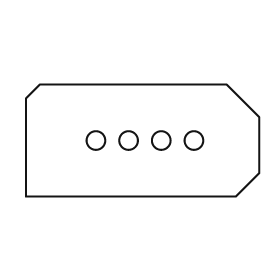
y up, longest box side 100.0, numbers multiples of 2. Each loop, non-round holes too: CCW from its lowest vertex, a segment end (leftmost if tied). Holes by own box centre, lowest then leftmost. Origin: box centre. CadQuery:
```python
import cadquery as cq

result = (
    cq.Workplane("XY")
    .moveTo(-50.0, -24.0)
    .lineTo(40.0, -24.0)
    .lineTo(50.0, -14.0)
    .lineTo(50.0, 10.0)
    .lineTo(36.0, 24.0)
    .lineTo(-44.0, 24.0)
    .lineTo(-50.0, 18.0)
    .close()
    .moveTo(-20.0, 0.0)
    .circle(4.0)
    .moveTo(-6.0, 0.0)
    .circle(4.0)
    .moveTo(8.0, 0.0)
    .circle(4.0)
    .moveTo(22.0, 0.0)
    .circle(4.0)
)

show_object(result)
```